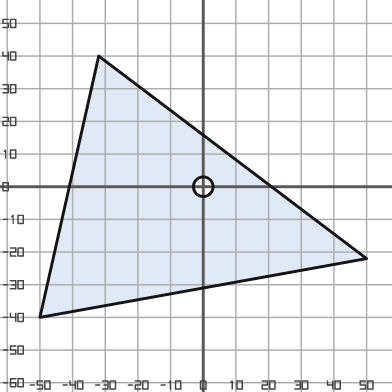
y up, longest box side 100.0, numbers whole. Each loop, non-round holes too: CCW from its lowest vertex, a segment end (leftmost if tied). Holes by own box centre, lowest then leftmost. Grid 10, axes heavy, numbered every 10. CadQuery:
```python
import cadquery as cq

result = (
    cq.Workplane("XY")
    .moveTo(-50.0, -40.0)
    .lineTo(50.0, -22.0)
    .lineTo(-32.0, 40.0)
    .close()
    .moveTo(0.0, 0.0)
    .circle(3.0)
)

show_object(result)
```